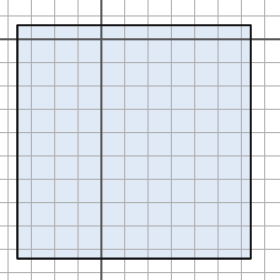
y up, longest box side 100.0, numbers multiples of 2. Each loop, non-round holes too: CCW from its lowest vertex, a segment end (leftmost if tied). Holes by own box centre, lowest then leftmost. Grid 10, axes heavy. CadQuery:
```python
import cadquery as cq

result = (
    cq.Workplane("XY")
    .moveTo(-36.0, -94.0)
    .lineTo(64.0, -94.0)
    .lineTo(64.0, 6.0)
    .lineTo(-36.0, 6.0)
    .close()
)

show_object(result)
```